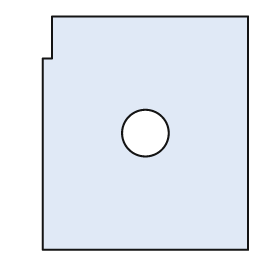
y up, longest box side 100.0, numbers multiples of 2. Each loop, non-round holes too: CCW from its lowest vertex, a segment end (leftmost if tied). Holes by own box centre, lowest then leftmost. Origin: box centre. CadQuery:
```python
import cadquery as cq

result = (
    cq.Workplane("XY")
    .moveTo(-44.0, -50.0)
    .lineTo(44.0, -50.0)
    .lineTo(44.0, 50.0)
    .lineTo(-40.0, 50.0)
    .lineTo(-40.0, 32.0)
    .lineTo(-44.0, 32.0)
    .close()
    .moveTo(0.0, 0.0)
    .circle(10.0)
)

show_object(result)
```